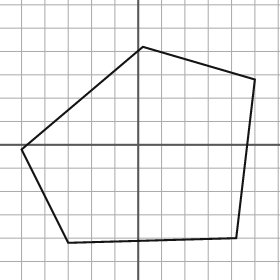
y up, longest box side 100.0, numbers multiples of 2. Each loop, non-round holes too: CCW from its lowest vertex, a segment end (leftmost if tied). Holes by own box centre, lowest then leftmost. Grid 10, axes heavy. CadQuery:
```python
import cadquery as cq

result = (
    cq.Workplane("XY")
    .moveTo(-30.0, -42.0)
    .lineTo(42.0, -40.0)
    .lineTo(50.0, 28.0)
    .lineTo(2.0, 42.0)
    .lineTo(-50.0, -2.0)
    .close()
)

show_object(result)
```